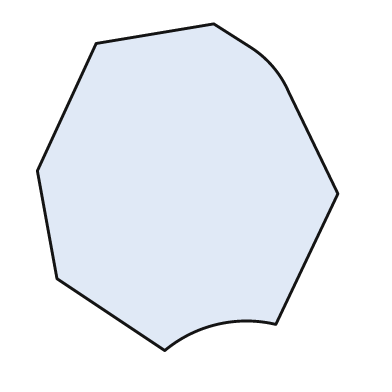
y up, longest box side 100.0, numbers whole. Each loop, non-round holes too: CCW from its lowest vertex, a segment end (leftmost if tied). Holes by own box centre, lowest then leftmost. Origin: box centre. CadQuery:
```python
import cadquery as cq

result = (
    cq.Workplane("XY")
    .moveTo(-7.0, -50.0)
    .threePointArc((9.0, -42.0), (27.0, -42.0))
    .lineTo(46.0, -2.0)
    .lineTo(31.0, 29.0)
    .threePointArc((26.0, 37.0), (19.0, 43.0))
    .lineTo(8.0, 50.0)
    .lineTo(-28.0, 44.0)
    .lineTo(-46.0, 5.0)
    .lineTo(-40.0, -28.0)
    .close()
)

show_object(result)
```